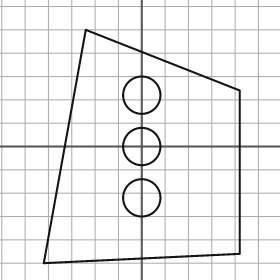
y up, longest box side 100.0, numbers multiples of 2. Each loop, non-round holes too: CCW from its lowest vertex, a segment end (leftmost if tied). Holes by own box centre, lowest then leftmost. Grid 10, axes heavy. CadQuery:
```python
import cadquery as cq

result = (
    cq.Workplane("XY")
    .moveTo(-42.0, -50.0)
    .lineTo(42.0, -46.0)
    .lineTo(42.0, 24.0)
    .lineTo(-24.0, 50.0)
    .close()
    .moveTo(0.0, -22.0)
    .circle(8.0)
    .moveTo(0.0, 0.0)
    .circle(8.0)
    .moveTo(0.0, 22.0)
    .circle(8.0)
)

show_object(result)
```